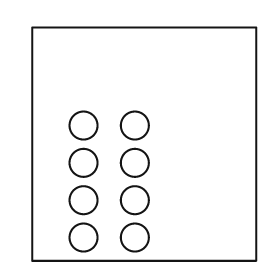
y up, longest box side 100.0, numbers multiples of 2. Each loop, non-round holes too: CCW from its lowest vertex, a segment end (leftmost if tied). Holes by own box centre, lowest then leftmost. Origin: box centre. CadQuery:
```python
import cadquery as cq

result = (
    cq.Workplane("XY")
    .moveTo(-48.0, -50.0)
    .lineTo(48.0, -50.0)
    .lineTo(48.0, 50.0)
    .lineTo(-48.0, 50.0)
    .close()
    .moveTo(-26.0, -40.0)
    .circle(6.0)
    .moveTo(-4.0, -40.0)
    .circle(6.0)
    .moveTo(-26.0, -24.0)
    .circle(6.0)
    .moveTo(-4.0, -24.0)
    .circle(6.0)
    .moveTo(-26.0, -8.0)
    .circle(6.0)
    .moveTo(-4.0, -8.0)
    .circle(6.0)
    .moveTo(-26.0, 8.0)
    .circle(6.0)
    .moveTo(-4.0, 8.0)
    .circle(6.0)
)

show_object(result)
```